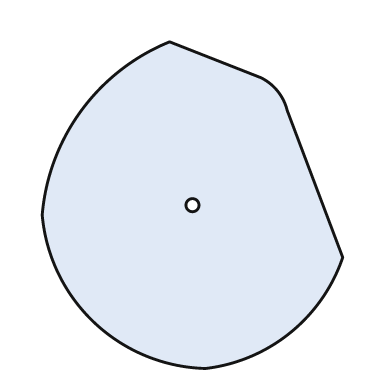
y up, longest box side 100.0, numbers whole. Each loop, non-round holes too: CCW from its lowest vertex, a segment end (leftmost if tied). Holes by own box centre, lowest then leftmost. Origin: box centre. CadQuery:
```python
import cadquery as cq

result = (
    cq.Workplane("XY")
    .moveTo(4.0, -50.0)
    .threePointArc((30.0, -39.0), (46.0, -16.0))
    .lineTo(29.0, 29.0)
    .threePointArc((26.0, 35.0), (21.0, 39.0))
    .lineTo(-7.0, 50.0)
    .threePointArc((-34.0, 29.0), (-46.0, -3.0))
    .threePointArc((-30.0, -36.0), (4.0, -50.0))
    .close()
    .moveTo(0.0, 0.0)
    .circle(2.0)
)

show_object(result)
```